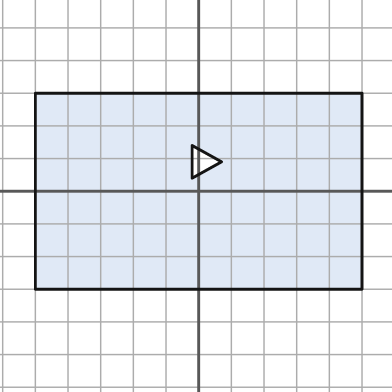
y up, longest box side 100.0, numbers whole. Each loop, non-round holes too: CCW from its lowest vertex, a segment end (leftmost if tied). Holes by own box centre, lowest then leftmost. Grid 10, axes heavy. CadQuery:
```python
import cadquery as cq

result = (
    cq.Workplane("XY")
    .moveTo(-50.0, -30.0)
    .lineTo(50.0, -30.0)
    .lineTo(50.0, 30.0)
    .lineTo(-50.0, 30.0)
    .close()
    .moveTo(-2.0, 4.0)
    .lineTo(7.0, 9.0)
    .lineTo(-2.0, 14.0)
    .close()
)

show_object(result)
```